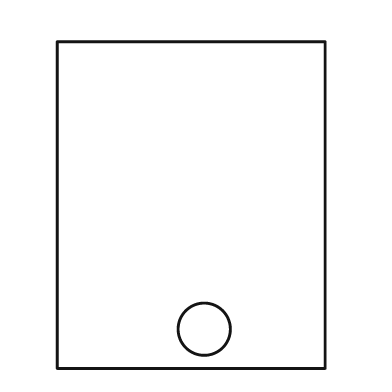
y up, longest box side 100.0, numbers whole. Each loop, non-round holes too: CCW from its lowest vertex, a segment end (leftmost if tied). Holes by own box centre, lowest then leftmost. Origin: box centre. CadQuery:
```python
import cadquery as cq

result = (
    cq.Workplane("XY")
    .moveTo(-41.0, -50.0)
    .lineTo(41.0, -50.0)
    .lineTo(41.0, 50.0)
    .lineTo(-41.0, 50.0)
    .close()
    .moveTo(4.0, -38.0)
    .circle(8.0)
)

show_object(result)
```